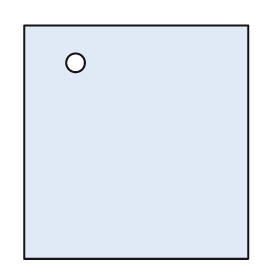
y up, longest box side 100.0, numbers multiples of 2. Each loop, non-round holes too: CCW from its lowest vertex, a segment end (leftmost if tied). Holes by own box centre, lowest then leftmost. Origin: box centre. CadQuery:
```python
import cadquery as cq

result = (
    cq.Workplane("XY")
    .moveTo(-48.0, -50.0)
    .lineTo(48.0, -50.0)
    .lineTo(48.0, 50.0)
    .lineTo(-48.0, 50.0)
    .close()
    .moveTo(-26.0, 34.0)
    .circle(4.0)
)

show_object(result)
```